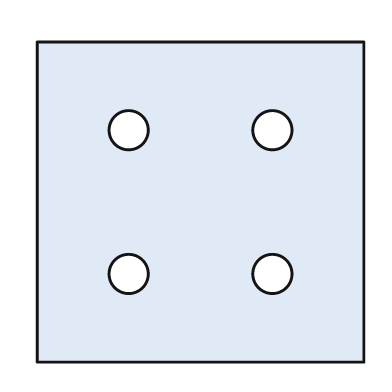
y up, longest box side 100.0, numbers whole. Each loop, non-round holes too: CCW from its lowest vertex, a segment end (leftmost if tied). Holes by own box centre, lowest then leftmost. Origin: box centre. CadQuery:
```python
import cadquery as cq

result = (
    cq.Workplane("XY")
    .moveTo(-50.0, -49.0)
    .lineTo(50.0, -49.0)
    .lineTo(50.0, 49.0)
    .lineTo(-50.0, 49.0)
    .close()
    .moveTo(-22.0, -22.0)
    .circle(6.0)
    .moveTo(22.0, -22.0)
    .circle(6.0)
    .moveTo(-22.0, 22.0)
    .circle(6.0)
    .moveTo(22.0, 22.0)
    .circle(6.0)
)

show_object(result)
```